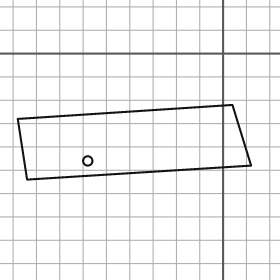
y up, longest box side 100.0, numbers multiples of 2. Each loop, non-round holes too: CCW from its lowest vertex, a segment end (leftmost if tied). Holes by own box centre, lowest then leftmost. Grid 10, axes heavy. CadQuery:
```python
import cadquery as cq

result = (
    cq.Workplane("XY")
    .moveTo(-84.0, -54.0)
    .lineTo(12.0, -48.0)
    .lineTo(4.0, -22.0)
    .lineTo(-88.0, -28.0)
    .close()
    .moveTo(-58.0, -46.0)
    .circle(2.0)
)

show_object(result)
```